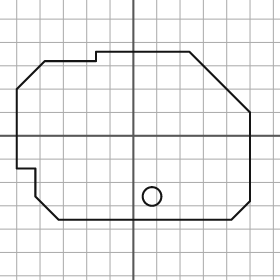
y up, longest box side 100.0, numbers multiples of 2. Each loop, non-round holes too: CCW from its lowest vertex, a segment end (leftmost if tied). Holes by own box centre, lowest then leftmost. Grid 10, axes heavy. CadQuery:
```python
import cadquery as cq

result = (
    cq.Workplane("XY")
    .moveTo(-32.0, -36.0)
    .lineTo(42.0, -36.0)
    .lineTo(50.0, -28.0)
    .lineTo(50.0, 10.0)
    .lineTo(24.0, 36.0)
    .lineTo(-16.0, 36.0)
    .lineTo(-16.0, 32.0)
    .lineTo(-38.0, 32.0)
    .lineTo(-50.0, 20.0)
    .lineTo(-50.0, -14.0)
    .lineTo(-42.0, -14.0)
    .lineTo(-42.0, -26.0)
    .close()
    .moveTo(8.0, -26.0)
    .circle(4.0)
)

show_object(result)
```